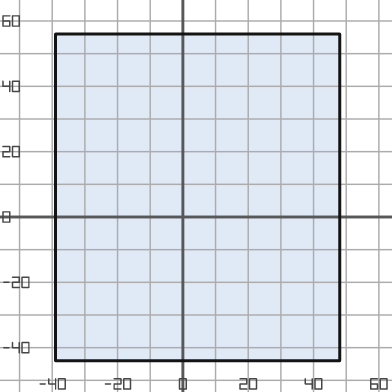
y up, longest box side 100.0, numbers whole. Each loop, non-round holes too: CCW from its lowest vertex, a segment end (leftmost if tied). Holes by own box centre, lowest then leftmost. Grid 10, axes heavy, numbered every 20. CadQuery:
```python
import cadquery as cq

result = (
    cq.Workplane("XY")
    .moveTo(-39.0, -44.0)
    .lineTo(48.0, -44.0)
    .lineTo(48.0, 56.0)
    .lineTo(-39.0, 56.0)
    .close()
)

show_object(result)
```